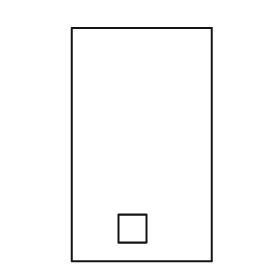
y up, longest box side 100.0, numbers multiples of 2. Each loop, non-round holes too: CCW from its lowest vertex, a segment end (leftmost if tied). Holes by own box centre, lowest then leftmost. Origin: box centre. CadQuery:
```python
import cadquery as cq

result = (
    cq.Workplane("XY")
    .moveTo(-30.0, -50.0)
    .lineTo(30.0, -50.0)
    .lineTo(30.0, 50.0)
    .lineTo(-30.0, 50.0)
    .close()
    .moveTo(-10.0, -42.0)
    .lineTo(2.0, -42.0)
    .lineTo(2.0, -30.0)
    .lineTo(-10.0, -30.0)
    .close()
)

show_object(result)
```